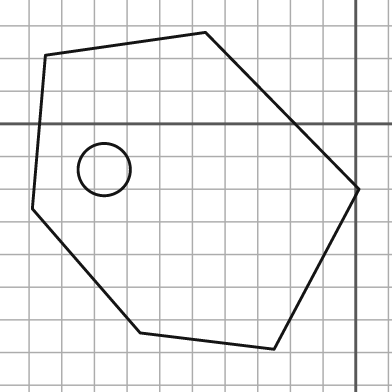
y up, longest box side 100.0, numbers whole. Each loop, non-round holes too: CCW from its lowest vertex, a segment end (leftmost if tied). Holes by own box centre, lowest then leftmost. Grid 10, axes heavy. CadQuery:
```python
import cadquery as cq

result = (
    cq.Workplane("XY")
    .moveTo(-25.0, -69.0)
    .lineTo(1.0, -20.0)
    .lineTo(-46.0, 28.0)
    .lineTo(-95.0, 21.0)
    .lineTo(-99.0, -26.0)
    .lineTo(-66.0, -64.0)
    .close()
    .moveTo(-77.0, -14.0)
    .circle(8.0)
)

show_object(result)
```